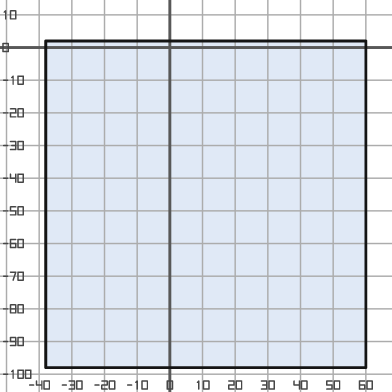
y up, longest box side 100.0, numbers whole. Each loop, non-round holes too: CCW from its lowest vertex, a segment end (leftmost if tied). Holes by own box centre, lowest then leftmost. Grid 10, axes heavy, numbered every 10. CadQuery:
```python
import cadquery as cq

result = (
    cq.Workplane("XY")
    .moveTo(-38.0, -98.0)
    .lineTo(60.0, -98.0)
    .lineTo(60.0, 2.0)
    .lineTo(-38.0, 2.0)
    .close()
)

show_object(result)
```